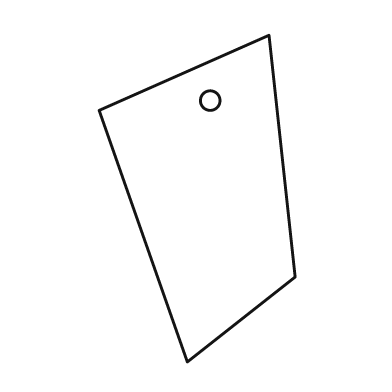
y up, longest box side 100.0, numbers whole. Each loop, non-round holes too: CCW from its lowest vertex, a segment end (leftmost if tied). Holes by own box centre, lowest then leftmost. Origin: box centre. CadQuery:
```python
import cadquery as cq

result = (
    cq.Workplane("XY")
    .moveTo(-3.0, -50.0)
    .lineTo(30.0, -24.0)
    .lineTo(22.0, 50.0)
    .lineTo(-30.0, 27.0)
    .close()
    .moveTo(4.0, 30.0)
    .circle(3.0)
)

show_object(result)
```